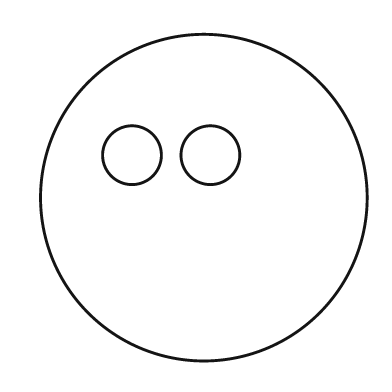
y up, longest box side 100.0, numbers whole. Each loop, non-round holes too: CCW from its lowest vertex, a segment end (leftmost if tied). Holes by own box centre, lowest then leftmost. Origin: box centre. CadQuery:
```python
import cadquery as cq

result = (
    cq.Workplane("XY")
    .moveTo(0.0, 0.0)
    .circle(50.0)
    .moveTo(-22.0, 13.0)
    .circle(9.0)
    .moveTo(2.0, 13.0)
    .circle(9.0)
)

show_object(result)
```